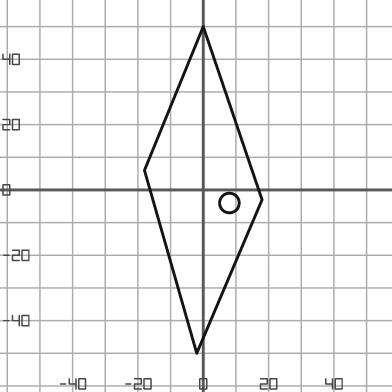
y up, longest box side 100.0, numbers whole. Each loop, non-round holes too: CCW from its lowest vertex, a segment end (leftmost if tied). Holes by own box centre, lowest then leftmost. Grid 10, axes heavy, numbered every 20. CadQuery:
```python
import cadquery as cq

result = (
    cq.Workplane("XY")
    .moveTo(-2.0, -50.0)
    .lineTo(18.0, -3.0)
    .lineTo(0.0, 50.0)
    .lineTo(-18.0, 6.0)
    .close()
    .moveTo(8.0, -4.0)
    .circle(3.0)
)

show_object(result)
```